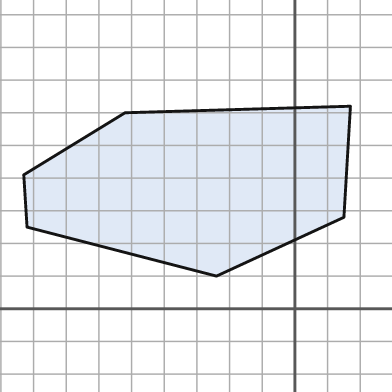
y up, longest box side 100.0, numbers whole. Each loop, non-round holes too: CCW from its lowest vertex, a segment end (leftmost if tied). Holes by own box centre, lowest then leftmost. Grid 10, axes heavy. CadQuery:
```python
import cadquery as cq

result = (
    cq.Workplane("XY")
    .moveTo(-24.0, 10.0)
    .lineTo(15.0, 28.0)
    .lineTo(17.0, 62.0)
    .lineTo(-52.0, 60.0)
    .lineTo(-83.0, 41.0)
    .lineTo(-82.0, 25.0)
    .close()
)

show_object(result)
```